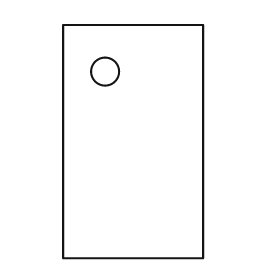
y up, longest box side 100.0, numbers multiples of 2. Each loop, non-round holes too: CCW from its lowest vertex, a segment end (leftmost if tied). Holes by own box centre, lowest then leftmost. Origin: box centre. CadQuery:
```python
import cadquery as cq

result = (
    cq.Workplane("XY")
    .moveTo(-30.0, -50.0)
    .lineTo(30.0, -50.0)
    .lineTo(30.0, 50.0)
    .lineTo(-30.0, 50.0)
    .close()
    .moveTo(-12.0, 30.0)
    .circle(6.0)
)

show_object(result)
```